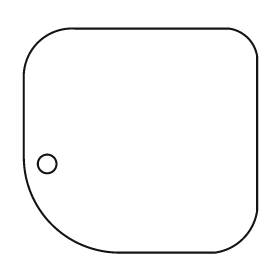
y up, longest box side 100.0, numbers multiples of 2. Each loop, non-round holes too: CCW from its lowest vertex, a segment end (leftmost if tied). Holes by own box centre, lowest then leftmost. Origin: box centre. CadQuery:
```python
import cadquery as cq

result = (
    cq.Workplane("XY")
    .moveTo(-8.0, -48.0)
    .lineTo(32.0, -48.0)
    .threePointArc((44.0, -42.0), (50.0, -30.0))
    .lineTo(50.0, 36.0)
    .threePointArc((46.0, 44.0), (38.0, 48.0))
    .lineTo(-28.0, 48.0)
    .threePointArc((-44.0, 42.0), (-50.0, 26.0))
    .lineTo(-50.0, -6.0)
    .threePointArc((-38.0, -36.0), (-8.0, -48.0))
    .close()
    .moveTo(-40.0, -10.0)
    .circle(4.0)
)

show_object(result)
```